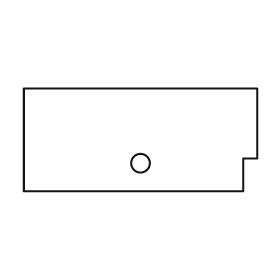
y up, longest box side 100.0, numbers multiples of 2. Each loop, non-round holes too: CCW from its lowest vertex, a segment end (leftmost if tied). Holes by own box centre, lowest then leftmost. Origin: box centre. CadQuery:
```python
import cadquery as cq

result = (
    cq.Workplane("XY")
    .moveTo(-50.0, -22.0)
    .lineTo(44.0, -22.0)
    .lineTo(44.0, -8.0)
    .lineTo(50.0, -8.0)
    .lineTo(50.0, 22.0)
    .lineTo(-50.0, 22.0)
    .close()
    .moveTo(0.0, -10.0)
    .circle(4.0)
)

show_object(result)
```